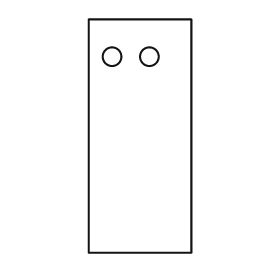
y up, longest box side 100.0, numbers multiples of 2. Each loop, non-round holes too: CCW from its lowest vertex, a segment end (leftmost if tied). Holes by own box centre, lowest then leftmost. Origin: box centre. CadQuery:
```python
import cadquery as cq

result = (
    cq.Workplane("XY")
    .moveTo(-22.0, -50.0)
    .lineTo(22.0, -50.0)
    .lineTo(22.0, 50.0)
    .lineTo(-22.0, 50.0)
    .close()
    .moveTo(-12.0, 34.0)
    .circle(4.0)
    .moveTo(4.0, 34.0)
    .circle(4.0)
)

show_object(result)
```